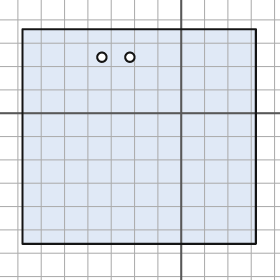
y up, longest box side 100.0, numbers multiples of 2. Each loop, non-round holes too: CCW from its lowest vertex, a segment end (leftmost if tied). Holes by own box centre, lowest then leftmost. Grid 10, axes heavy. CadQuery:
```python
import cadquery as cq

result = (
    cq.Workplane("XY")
    .moveTo(-68.0, -56.0)
    .lineTo(32.0, -56.0)
    .lineTo(32.0, 36.0)
    .lineTo(-68.0, 36.0)
    .close()
    .moveTo(-34.0, 24.0)
    .circle(2.0)
    .moveTo(-22.0, 24.0)
    .circle(2.0)
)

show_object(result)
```